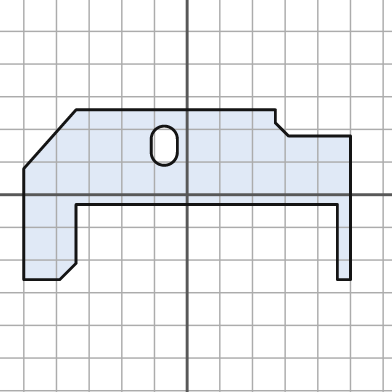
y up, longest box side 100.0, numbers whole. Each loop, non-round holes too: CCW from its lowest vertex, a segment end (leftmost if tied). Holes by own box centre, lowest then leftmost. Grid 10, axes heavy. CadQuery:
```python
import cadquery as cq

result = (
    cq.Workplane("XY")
    .moveTo(-50.0, -26.0)
    .lineTo(-39.0, -26.0)
    .lineTo(-34.0, -21.0)
    .lineTo(-34.0, -3.0)
    .lineTo(46.0, -3.0)
    .lineTo(46.0, -26.0)
    .lineTo(50.0, -26.0)
    .lineTo(50.0, 18.0)
    .lineTo(31.0, 18.0)
    .lineTo(27.0, 22.0)
    .lineTo(27.0, 26.0)
    .lineTo(-34.0, 26.0)
    .lineTo(-50.0, 8.0)
    .close()
    .moveTo(-11.0, 13.0)
    .threePointArc((-7.0, 9.0), (-3.0, 13.0))
    .lineTo(-3.0, 17.0)
    .threePointArc((-7.0, 21.0), (-11.0, 17.0))
    .close()
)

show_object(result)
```